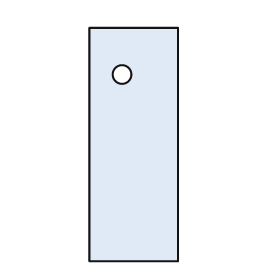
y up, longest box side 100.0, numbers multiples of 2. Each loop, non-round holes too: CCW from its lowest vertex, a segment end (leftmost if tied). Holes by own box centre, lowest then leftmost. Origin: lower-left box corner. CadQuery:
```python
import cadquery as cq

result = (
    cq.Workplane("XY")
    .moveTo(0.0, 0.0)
    .lineTo(38.0, 0.0)
    .lineTo(38.0, 100.0)
    .lineTo(0.0, 100.0)
    .close()
    .moveTo(14.0, 80.0)
    .circle(4.0)
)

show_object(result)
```